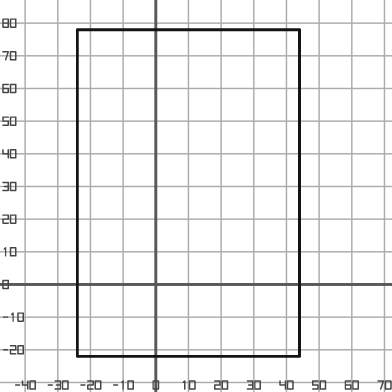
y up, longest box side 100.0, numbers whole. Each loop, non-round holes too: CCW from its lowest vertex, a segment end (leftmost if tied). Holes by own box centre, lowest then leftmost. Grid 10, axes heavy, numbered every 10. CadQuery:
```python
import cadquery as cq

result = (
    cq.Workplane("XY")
    .moveTo(-24.0, -22.0)
    .lineTo(44.0, -22.0)
    .lineTo(44.0, 78.0)
    .lineTo(-24.0, 78.0)
    .close()
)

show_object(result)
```